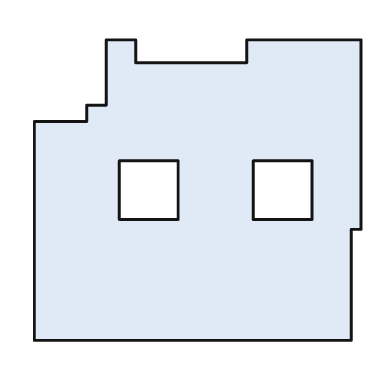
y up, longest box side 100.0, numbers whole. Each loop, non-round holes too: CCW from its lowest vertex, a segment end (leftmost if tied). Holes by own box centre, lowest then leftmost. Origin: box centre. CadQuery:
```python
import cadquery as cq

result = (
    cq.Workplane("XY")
    .moveTo(-50.0, -46.0)
    .lineTo(47.0, -46.0)
    .lineTo(47.0, -12.0)
    .lineTo(50.0, -12.0)
    .lineTo(50.0, 46.0)
    .lineTo(15.0, 46.0)
    .lineTo(15.0, 39.0)
    .lineTo(-19.0, 39.0)
    .lineTo(-19.0, 46.0)
    .lineTo(-28.0, 46.0)
    .lineTo(-28.0, 26.0)
    .lineTo(-34.0, 26.0)
    .lineTo(-34.0, 21.0)
    .lineTo(-50.0, 21.0)
    .close()
    .moveTo(-24.0, -9.0)
    .lineTo(-6.0, -9.0)
    .lineTo(-6.0, 9.0)
    .lineTo(-24.0, 9.0)
    .close()
    .moveTo(17.0, -9.0)
    .lineTo(35.0, -9.0)
    .lineTo(35.0, 9.0)
    .lineTo(17.0, 9.0)
    .close()
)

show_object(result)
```